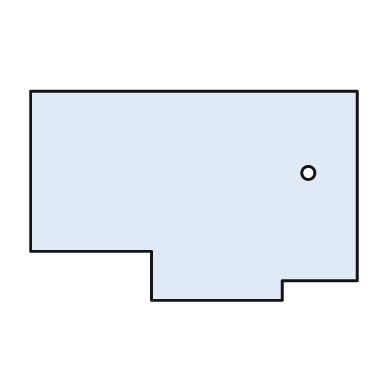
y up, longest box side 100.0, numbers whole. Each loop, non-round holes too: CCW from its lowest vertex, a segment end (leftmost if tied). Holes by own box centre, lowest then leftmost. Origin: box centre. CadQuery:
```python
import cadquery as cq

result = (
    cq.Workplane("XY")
    .moveTo(-13.0, -32.0)
    .lineTo(27.0, -32.0)
    .lineTo(27.0, -26.0)
    .lineTo(50.0, -26.0)
    .lineTo(50.0, 32.0)
    .lineTo(-50.0, 32.0)
    .lineTo(-50.0, -17.0)
    .lineTo(-13.0, -17.0)
    .close()
    .moveTo(35.0, 7.0)
    .circle(2.0)
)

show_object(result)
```